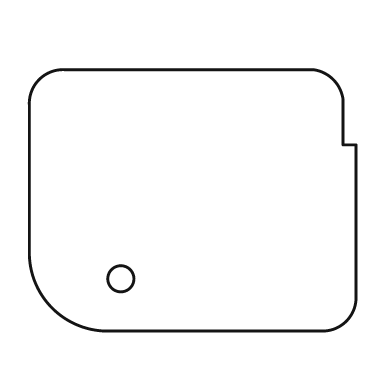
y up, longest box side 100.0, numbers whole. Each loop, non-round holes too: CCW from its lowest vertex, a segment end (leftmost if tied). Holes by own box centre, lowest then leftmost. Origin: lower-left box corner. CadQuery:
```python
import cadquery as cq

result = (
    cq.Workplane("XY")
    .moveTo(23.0, 0.0)
    .lineTo(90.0, 0.0)
    .threePointArc((97.0, 3.0), (100.0, 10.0))
    .lineTo(100.0, 57.0)
    .lineTo(96.0, 57.0)
    .lineTo(96.0, 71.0)
    .threePointArc((93.0, 77.0), (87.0, 80.0))
    .lineTo(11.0, 80.0)
    .threePointArc((3.0, 77.0), (0.0, 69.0))
    .lineTo(0.0, 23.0)
    .threePointArc((7.0, 7.0), (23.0, 0.0))
    .close()
    .moveTo(28.0, 16.0)
    .circle(4.0)
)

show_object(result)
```